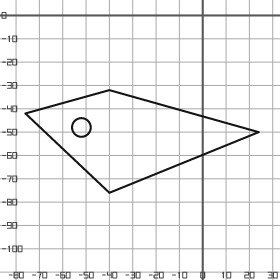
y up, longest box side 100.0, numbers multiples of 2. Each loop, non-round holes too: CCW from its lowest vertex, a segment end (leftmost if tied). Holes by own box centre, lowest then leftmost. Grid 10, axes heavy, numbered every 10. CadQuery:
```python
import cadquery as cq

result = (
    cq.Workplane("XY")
    .moveTo(-40.0, -76.0)
    .lineTo(24.0, -50.0)
    .lineTo(-40.0, -32.0)
    .lineTo(-76.0, -42.0)
    .close()
    .moveTo(-52.0, -48.0)
    .circle(4.0)
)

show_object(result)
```